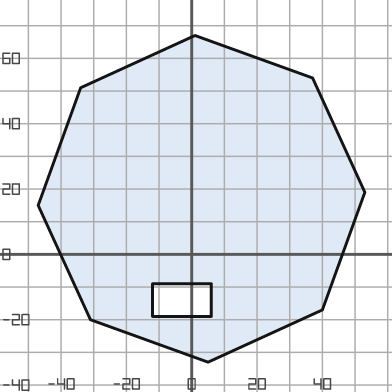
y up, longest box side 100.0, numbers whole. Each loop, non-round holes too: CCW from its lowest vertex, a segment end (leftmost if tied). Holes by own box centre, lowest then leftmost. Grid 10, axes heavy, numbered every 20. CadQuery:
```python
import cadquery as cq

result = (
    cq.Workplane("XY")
    .moveTo(5.0, -33.0)
    .lineTo(40.0, -17.0)
    .lineTo(53.0, 19.0)
    .lineTo(37.0, 54.0)
    .lineTo(1.0, 67.0)
    .lineTo(-34.0, 51.0)
    .lineTo(-47.0, 15.0)
    .lineTo(-31.0, -20.0)
    .close()
    .moveTo(-12.0, -19.0)
    .lineTo(6.0, -19.0)
    .lineTo(6.0, -9.0)
    .lineTo(-12.0, -9.0)
    .close()
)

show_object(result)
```